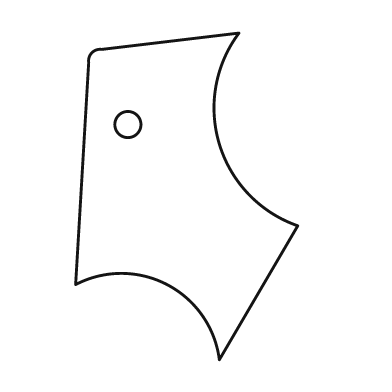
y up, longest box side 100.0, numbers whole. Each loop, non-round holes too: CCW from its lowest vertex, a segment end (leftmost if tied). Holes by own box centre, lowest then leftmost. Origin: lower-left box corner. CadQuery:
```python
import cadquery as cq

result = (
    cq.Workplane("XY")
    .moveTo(44.0, 0.0)
    .lineTo(68.0, 41.0)
    .threePointArc((44.0, 66.0), (50.0, 100.0))
    .lineTo(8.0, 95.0)
    .threePointArc((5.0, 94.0), (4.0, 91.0))
    .lineTo(0.0, 23.0)
    .threePointArc((28.0, 23.0), (44.0, 0.0))
    .close()
    .moveTo(16.0, 72.0)
    .circle(4.0)
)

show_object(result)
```